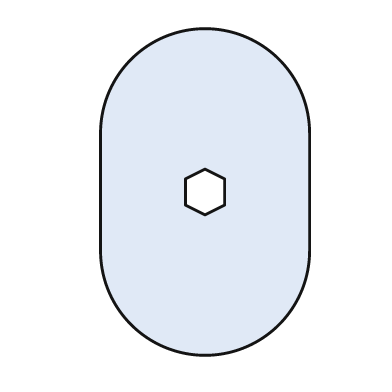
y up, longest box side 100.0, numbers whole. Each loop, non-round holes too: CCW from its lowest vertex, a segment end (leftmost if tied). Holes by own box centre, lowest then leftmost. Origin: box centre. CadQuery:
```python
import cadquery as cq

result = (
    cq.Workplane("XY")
    .moveTo(-32.0, -18.0)
    .threePointArc((0.0, -50.0), (32.0, -18.0))
    .lineTo(32.0, 18.0)
    .threePointArc((0.0, 50.0), (-32.0, 18.0))
    .close()
    .moveTo(0.0, -7.0)
    .lineTo(6.0, -4.0)
    .lineTo(6.0, 4.0)
    .lineTo(0.0, 7.0)
    .lineTo(-6.0, 4.0)
    .lineTo(-6.0, -4.0)
    .close()
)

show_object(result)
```